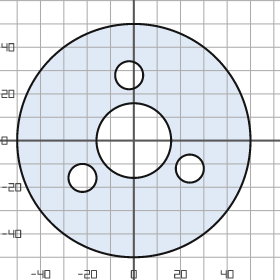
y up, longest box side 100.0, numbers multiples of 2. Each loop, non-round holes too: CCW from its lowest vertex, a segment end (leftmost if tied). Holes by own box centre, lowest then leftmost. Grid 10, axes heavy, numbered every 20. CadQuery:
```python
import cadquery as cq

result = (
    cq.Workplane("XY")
    .moveTo(0.0, 0.0)
    .circle(50.0)
    .moveTo(-22.0, -16.0)
    .circle(6.0)
    .moveTo(24.0, -12.0)
    .circle(6.0)
    .moveTo(0.0, 0.0)
    .circle(16.0)
    .moveTo(-2.0, 28.0)
    .circle(6.0)
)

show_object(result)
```